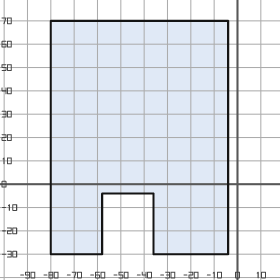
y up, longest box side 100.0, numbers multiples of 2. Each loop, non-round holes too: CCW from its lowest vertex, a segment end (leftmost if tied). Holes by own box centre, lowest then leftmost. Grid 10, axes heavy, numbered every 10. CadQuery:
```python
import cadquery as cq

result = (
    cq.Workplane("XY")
    .moveTo(-80.0, -30.0)
    .lineTo(-58.0, -30.0)
    .lineTo(-58.0, -4.0)
    .lineTo(-36.0, -4.0)
    .lineTo(-36.0, -30.0)
    .lineTo(-4.0, -30.0)
    .lineTo(-4.0, 70.0)
    .lineTo(-80.0, 70.0)
    .close()
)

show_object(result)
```